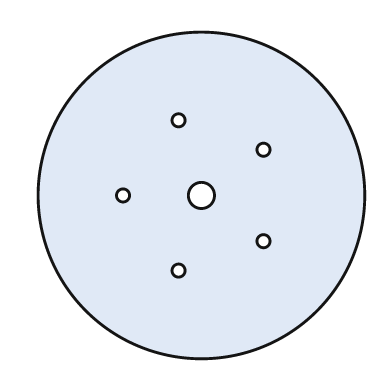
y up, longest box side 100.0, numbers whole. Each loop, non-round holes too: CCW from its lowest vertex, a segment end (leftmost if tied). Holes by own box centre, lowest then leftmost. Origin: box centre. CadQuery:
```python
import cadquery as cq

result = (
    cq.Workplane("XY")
    .moveTo(0.0, 0.0)
    .circle(50.0)
    .moveTo(-7.0, -23.0)
    .circle(2.0)
    .moveTo(19.0, -14.0)
    .circle(2.0)
    .moveTo(-24.0, 0.0)
    .circle(2.0)
    .moveTo(0.0, 0.0)
    .circle(4.0)
    .moveTo(19.0, 14.0)
    .circle(2.0)
    .moveTo(-7.0, 23.0)
    .circle(2.0)
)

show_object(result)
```